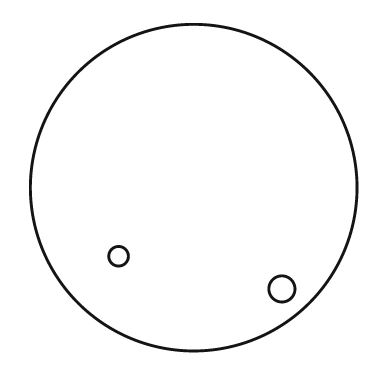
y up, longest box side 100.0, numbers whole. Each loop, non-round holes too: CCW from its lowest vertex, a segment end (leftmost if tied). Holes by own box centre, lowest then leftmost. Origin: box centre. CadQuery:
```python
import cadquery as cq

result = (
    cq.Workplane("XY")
    .moveTo(0.0, 0.0)
    .circle(50.0)
    .moveTo(27.0, -31.0)
    .circle(4.0)
    .moveTo(-23.0, -21.0)
    .circle(3.0)
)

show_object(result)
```